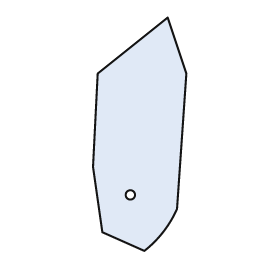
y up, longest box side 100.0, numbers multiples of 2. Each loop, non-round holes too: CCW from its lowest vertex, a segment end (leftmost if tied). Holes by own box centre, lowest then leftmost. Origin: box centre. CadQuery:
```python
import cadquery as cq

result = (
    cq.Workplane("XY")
    .moveTo(2.0, -50.0)
    .threePointArc((10.0, -42.0), (16.0, -32.0))
    .lineTo(20.0, 26.0)
    .lineTo(12.0, 50.0)
    .lineTo(-18.0, 26.0)
    .lineTo(-20.0, -14.0)
    .lineTo(-16.0, -42.0)
    .close()
    .moveTo(-4.0, -26.0)
    .circle(2.0)
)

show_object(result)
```